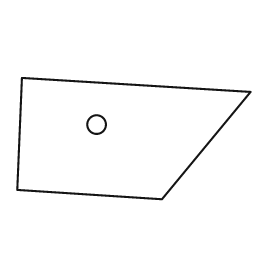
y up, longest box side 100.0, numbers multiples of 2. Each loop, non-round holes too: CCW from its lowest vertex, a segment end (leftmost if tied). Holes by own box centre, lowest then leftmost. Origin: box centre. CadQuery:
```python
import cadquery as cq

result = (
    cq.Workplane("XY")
    .moveTo(12.0, -26.0)
    .lineTo(50.0, 20.0)
    .lineTo(-48.0, 26.0)
    .lineTo(-50.0, -22.0)
    .close()
    .moveTo(-16.0, 6.0)
    .circle(4.0)
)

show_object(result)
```